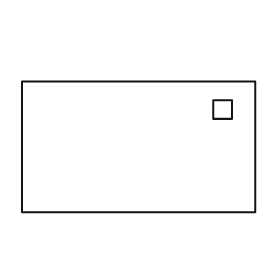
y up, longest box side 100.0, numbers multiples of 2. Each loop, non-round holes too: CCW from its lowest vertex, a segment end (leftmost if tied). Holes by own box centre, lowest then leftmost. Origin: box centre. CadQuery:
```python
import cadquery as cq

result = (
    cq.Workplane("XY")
    .moveTo(-50.0, -28.0)
    .lineTo(50.0, -28.0)
    .lineTo(50.0, 28.0)
    .lineTo(-50.0, 28.0)
    .close()
    .moveTo(32.0, 12.0)
    .lineTo(40.0, 12.0)
    .lineTo(40.0, 20.0)
    .lineTo(32.0, 20.0)
    .close()
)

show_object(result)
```